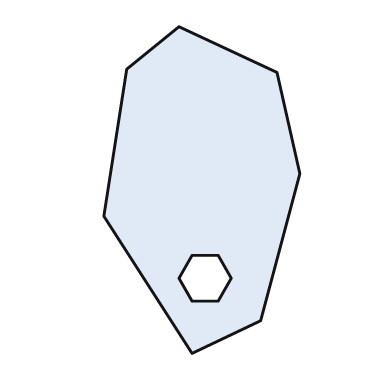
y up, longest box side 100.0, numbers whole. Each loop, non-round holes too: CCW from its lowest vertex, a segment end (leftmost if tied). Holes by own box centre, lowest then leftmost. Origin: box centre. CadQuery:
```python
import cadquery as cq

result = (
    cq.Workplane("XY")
    .moveTo(-3.0, -50.0)
    .lineTo(18.0, -40.0)
    .lineTo(30.0, 5.0)
    .lineTo(23.0, 36.0)
    .lineTo(-7.0, 50.0)
    .lineTo(-23.0, 37.0)
    .lineTo(-30.0, -8.0)
    .close()
    .moveTo(-3.0, -34.0)
    .lineTo(5.0, -34.0)
    .lineTo(9.0, -27.0)
    .lineTo(5.0, -20.0)
    .lineTo(-3.0, -20.0)
    .lineTo(-7.0, -27.0)
    .close()
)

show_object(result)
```